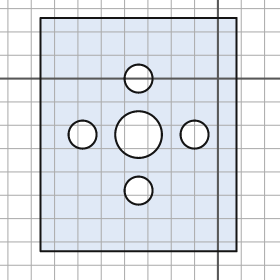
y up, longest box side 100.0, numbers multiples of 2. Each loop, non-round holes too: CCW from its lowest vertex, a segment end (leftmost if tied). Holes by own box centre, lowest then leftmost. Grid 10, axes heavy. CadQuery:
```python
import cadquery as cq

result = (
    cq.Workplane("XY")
    .moveTo(-76.0, -74.0)
    .lineTo(8.0, -74.0)
    .lineTo(8.0, 26.0)
    .lineTo(-76.0, 26.0)
    .close()
    .moveTo(-34.0, -48.0)
    .circle(6.0)
    .moveTo(-58.0, -24.0)
    .circle(6.0)
    .moveTo(-34.0, -24.0)
    .circle(10.0)
    .moveTo(-10.0, -24.0)
    .circle(6.0)
    .moveTo(-34.0, 0.0)
    .circle(6.0)
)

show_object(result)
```